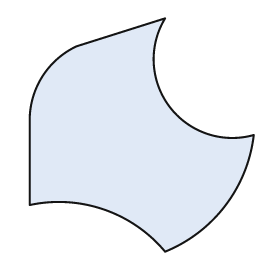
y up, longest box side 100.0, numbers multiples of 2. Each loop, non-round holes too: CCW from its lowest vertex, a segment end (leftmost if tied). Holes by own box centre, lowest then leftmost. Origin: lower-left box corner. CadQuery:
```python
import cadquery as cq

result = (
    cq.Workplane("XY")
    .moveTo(58.0, 0.0)
    .threePointArc((84.0, 20.0), (96.0, 50.0))
    .threePointArc((60.0, 62.0), (58.0, 100.0))
    .lineTo(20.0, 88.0)
    .threePointArc((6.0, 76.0), (0.0, 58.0))
    .lineTo(0.0, 20.0)
    .threePointArc((32.0, 18.0), (58.0, 0.0))
    .close()
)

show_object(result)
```